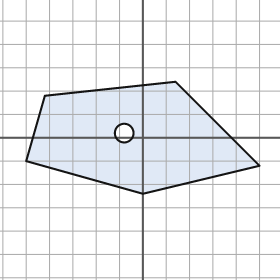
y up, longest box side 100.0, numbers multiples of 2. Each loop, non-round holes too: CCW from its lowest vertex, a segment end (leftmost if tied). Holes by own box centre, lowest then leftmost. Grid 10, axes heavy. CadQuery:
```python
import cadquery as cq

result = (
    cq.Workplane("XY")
    .moveTo(0.0, -24.0)
    .lineTo(50.0, -12.0)
    .lineTo(14.0, 24.0)
    .lineTo(-42.0, 18.0)
    .lineTo(-50.0, -10.0)
    .close()
    .moveTo(-8.0, 2.0)
    .circle(4.0)
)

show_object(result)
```